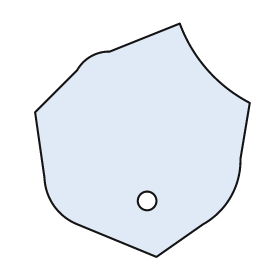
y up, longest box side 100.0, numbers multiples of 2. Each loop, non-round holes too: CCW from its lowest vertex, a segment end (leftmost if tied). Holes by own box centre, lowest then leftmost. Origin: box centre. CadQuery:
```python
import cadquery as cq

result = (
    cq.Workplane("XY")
    .moveTo(6.0, -50.0)
    .lineTo(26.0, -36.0)
    .threePointArc((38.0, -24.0), (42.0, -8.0))
    .lineTo(46.0, 16.0)
    .threePointArc((28.0, 30.0), (16.0, 50.0))
    .lineTo(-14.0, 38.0)
    .threePointArc((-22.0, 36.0), (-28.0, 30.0))
    .lineTo(-46.0, 12.0)
    .lineTo(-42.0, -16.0)
    .threePointArc((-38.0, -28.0), (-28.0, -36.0))
    .close()
    .moveTo(2.0, -26.0)
    .circle(4.0)
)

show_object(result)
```